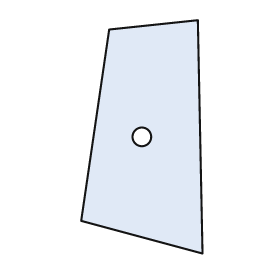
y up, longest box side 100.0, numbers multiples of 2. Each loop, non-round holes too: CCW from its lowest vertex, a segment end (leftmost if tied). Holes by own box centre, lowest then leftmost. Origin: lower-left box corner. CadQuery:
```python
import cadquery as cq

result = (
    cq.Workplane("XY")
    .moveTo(52.0, 0.0)
    .lineTo(50.0, 100.0)
    .lineTo(12.0, 96.0)
    .lineTo(0.0, 14.0)
    .close()
    .moveTo(26.0, 50.0)
    .circle(4.0)
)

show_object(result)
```